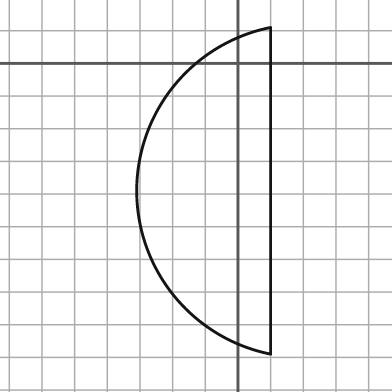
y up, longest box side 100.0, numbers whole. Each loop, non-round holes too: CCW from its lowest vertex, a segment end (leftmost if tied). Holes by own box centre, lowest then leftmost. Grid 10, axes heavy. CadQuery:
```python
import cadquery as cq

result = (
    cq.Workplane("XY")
    .moveTo(10.0, -89.0)
    .lineTo(10.0, 11.0)
    .threePointArc((-31.0, -39.0), (10.0, -89.0))
    .close()
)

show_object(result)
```